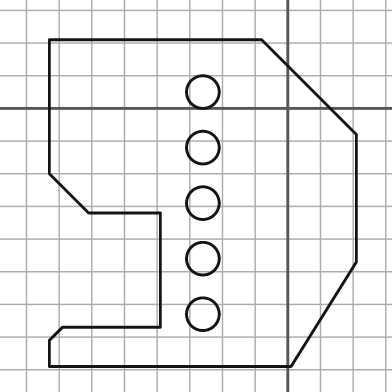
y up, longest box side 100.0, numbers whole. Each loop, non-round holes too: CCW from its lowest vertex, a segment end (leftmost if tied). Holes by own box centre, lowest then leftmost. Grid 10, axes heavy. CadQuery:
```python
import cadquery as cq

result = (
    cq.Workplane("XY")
    .moveTo(-73.0, -79.0)
    .lineTo(1.0, -79.0)
    .lineTo(21.0, -47.0)
    .lineTo(21.0, -8.0)
    .lineTo(-8.0, 21.0)
    .lineTo(-73.0, 21.0)
    .lineTo(-73.0, -20.0)
    .lineTo(-61.0, -32.0)
    .lineTo(-39.0, -32.0)
    .lineTo(-39.0, -67.0)
    .lineTo(-69.0, -67.0)
    .lineTo(-73.0, -71.0)
    .close()
    .moveTo(-26.0, -63.0)
    .circle(5.0)
    .moveTo(-26.0, -46.0)
    .circle(5.0)
    .moveTo(-26.0, -29.0)
    .circle(5.0)
    .moveTo(-26.0, -12.0)
    .circle(5.0)
    .moveTo(-26.0, 5.0)
    .circle(5.0)
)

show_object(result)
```